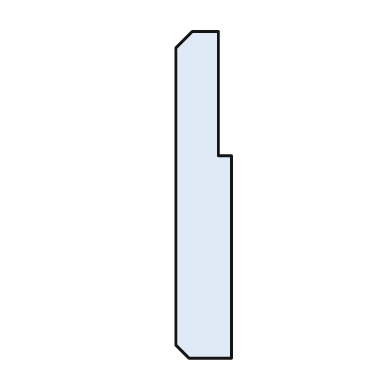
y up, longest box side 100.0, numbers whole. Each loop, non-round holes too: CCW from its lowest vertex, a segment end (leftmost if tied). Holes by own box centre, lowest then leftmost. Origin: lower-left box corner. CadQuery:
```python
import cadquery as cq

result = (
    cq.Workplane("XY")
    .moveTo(4.0, 0.0)
    .lineTo(17.0, 0.0)
    .lineTo(17.0, 62.0)
    .lineTo(13.0, 62.0)
    .lineTo(13.0, 100.0)
    .lineTo(5.0, 100.0)
    .lineTo(0.0, 95.0)
    .lineTo(0.0, 4.0)
    .close()
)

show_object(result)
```